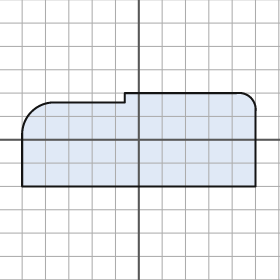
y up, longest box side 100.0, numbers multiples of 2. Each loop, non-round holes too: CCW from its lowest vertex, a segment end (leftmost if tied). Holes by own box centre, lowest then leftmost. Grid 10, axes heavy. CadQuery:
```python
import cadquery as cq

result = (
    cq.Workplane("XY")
    .moveTo(-50.0, -20.0)
    .lineTo(50.0, -20.0)
    .lineTo(50.0, 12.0)
    .threePointArc((48.0, 18.0), (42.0, 20.0))
    .lineTo(-6.0, 20.0)
    .lineTo(-6.0, 16.0)
    .lineTo(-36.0, 16.0)
    .threePointArc((-46.0, 12.0), (-50.0, 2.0))
    .close()
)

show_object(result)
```